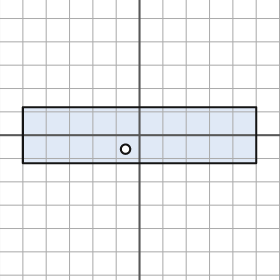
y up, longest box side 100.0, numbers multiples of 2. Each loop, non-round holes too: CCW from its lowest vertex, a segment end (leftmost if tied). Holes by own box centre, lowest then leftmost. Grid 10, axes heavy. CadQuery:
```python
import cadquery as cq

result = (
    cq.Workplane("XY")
    .moveTo(-50.0, -12.0)
    .lineTo(50.0, -12.0)
    .lineTo(50.0, 12.0)
    .lineTo(-50.0, 12.0)
    .close()
    .moveTo(-6.0, -6.0)
    .circle(2.0)
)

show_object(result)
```